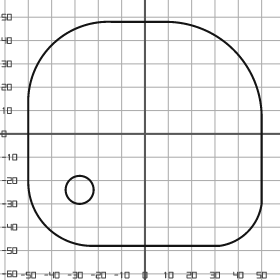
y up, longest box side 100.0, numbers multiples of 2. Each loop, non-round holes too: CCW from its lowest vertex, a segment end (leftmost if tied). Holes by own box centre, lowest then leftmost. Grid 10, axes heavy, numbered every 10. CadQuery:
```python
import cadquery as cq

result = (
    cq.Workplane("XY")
    .moveTo(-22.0, -48.0)
    .lineTo(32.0, -48.0)
    .threePointArc((44.0, -42.0), (50.0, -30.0))
    .lineTo(50.0, 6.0)
    .threePointArc((38.0, 36.0), (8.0, 48.0))
    .lineTo(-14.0, 48.0)
    .threePointArc((-40.0, 38.0), (-50.0, 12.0))
    .lineTo(-50.0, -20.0)
    .threePointArc((-42.0, -40.0), (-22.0, -48.0))
    .close()
    .moveTo(-28.0, -24.0)
    .circle(6.0)
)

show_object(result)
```